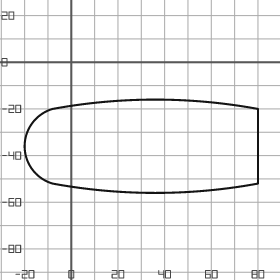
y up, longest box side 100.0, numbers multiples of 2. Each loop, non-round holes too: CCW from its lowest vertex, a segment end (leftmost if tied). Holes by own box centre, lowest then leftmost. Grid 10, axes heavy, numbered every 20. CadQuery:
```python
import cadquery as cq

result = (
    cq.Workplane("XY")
    .moveTo(-8.0, -52.0)
    .threePointArc((36.0, -56.0), (80.0, -52.0))
    .lineTo(80.0, -20.0)
    .threePointArc((36.0, -16.0), (-8.0, -20.0))
    .threePointArc((-20.0, -36.0), (-8.0, -52.0))
    .close()
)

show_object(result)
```